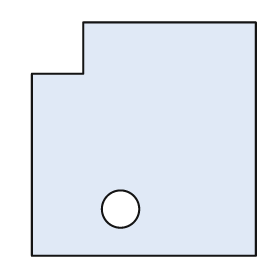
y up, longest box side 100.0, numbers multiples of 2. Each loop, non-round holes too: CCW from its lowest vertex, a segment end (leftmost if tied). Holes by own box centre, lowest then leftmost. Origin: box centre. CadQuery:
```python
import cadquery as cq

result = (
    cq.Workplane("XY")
    .moveTo(-48.0, -50.0)
    .lineTo(48.0, -50.0)
    .lineTo(48.0, 50.0)
    .lineTo(-26.0, 50.0)
    .lineTo(-26.0, 28.0)
    .lineTo(-48.0, 28.0)
    .close()
    .moveTo(-10.0, -30.0)
    .circle(8.0)
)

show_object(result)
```